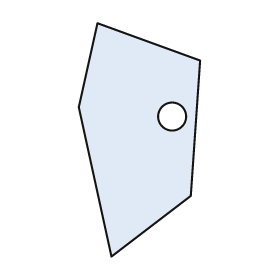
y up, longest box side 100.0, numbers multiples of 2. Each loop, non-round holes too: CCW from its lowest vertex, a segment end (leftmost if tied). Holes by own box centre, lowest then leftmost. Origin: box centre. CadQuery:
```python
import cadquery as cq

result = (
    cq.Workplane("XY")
    .moveTo(-12.0, -50.0)
    .lineTo(22.0, -24.0)
    .lineTo(26.0, 34.0)
    .lineTo(-18.0, 50.0)
    .lineTo(-26.0, 14.0)
    .close()
    .moveTo(14.0, 10.0)
    .circle(6.0)
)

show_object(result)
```